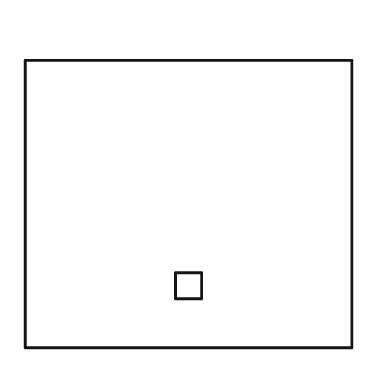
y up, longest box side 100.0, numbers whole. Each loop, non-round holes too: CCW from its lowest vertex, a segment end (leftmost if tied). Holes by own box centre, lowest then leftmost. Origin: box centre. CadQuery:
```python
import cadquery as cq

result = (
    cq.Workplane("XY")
    .moveTo(-50.0, -44.0)
    .lineTo(50.0, -44.0)
    .lineTo(50.0, 44.0)
    .lineTo(-50.0, 44.0)
    .close()
    .moveTo(-4.0, -29.0)
    .lineTo(4.0, -29.0)
    .lineTo(4.0, -21.0)
    .lineTo(-4.0, -21.0)
    .close()
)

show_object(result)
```